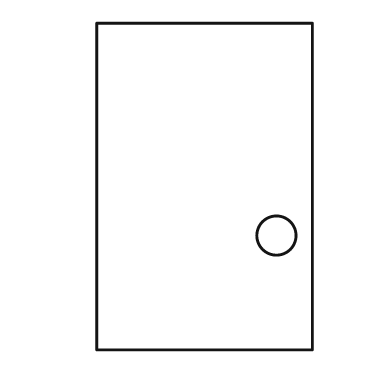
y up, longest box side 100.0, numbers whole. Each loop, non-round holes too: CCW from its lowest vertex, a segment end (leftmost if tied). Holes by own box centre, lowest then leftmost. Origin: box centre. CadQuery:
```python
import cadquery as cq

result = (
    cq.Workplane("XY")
    .moveTo(-33.0, -50.0)
    .lineTo(33.0, -50.0)
    .lineTo(33.0, 50.0)
    .lineTo(-33.0, 50.0)
    .close()
    .moveTo(22.0, -15.0)
    .circle(6.0)
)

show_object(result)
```